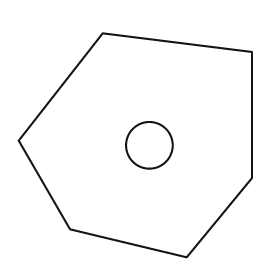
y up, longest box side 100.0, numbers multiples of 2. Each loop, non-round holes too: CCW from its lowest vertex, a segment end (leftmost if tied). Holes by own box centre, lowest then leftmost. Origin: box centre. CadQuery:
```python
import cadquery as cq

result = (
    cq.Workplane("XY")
    .moveTo(22.0, -48.0)
    .lineTo(50.0, -14.0)
    .lineTo(50.0, 40.0)
    .lineTo(-14.0, 48.0)
    .lineTo(-50.0, 2.0)
    .lineTo(-28.0, -36.0)
    .close()
    .moveTo(6.0, 0.0)
    .circle(10.0)
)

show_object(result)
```